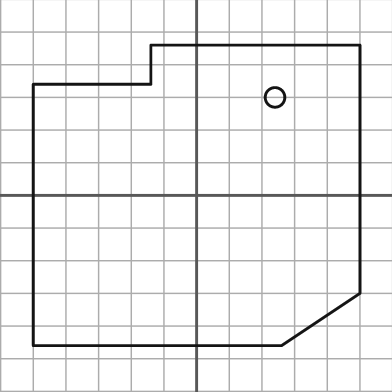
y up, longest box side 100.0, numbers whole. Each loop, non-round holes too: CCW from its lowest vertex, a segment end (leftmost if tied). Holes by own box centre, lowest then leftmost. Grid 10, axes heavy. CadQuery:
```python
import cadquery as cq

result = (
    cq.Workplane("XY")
    .moveTo(-50.0, -46.0)
    .lineTo(26.0, -46.0)
    .lineTo(50.0, -30.0)
    .lineTo(50.0, 46.0)
    .lineTo(-14.0, 46.0)
    .lineTo(-14.0, 34.0)
    .lineTo(-50.0, 34.0)
    .close()
    .moveTo(24.0, 30.0)
    .circle(3.0)
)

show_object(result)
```